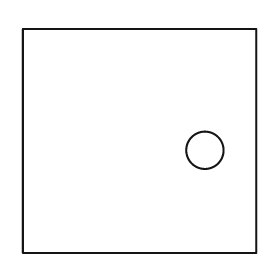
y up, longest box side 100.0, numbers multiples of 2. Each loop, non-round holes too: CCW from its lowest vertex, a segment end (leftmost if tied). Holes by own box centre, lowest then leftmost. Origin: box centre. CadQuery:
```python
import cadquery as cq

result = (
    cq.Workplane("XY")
    .moveTo(-50.0, -48.0)
    .lineTo(50.0, -48.0)
    .lineTo(50.0, 48.0)
    .lineTo(-50.0, 48.0)
    .close()
    .moveTo(28.0, -4.0)
    .circle(8.0)
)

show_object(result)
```